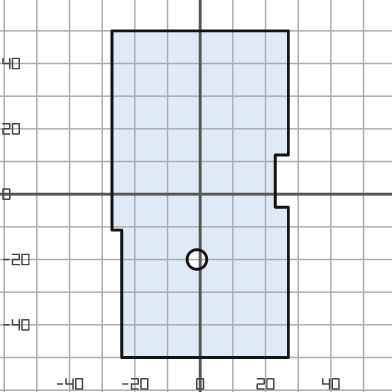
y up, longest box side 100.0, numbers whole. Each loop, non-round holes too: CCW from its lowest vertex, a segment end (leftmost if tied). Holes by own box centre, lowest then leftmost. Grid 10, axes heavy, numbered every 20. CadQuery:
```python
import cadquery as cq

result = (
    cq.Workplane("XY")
    .moveTo(-24.0, -50.0)
    .lineTo(27.0, -50.0)
    .lineTo(27.0, -4.0)
    .lineTo(23.0, -4.0)
    .lineTo(23.0, 12.0)
    .lineTo(27.0, 12.0)
    .lineTo(27.0, 50.0)
    .lineTo(-27.0, 50.0)
    .lineTo(-27.0, -11.0)
    .lineTo(-24.0, -11.0)
    .close()
    .moveTo(-1.0, -20.0)
    .circle(3.0)
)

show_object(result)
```